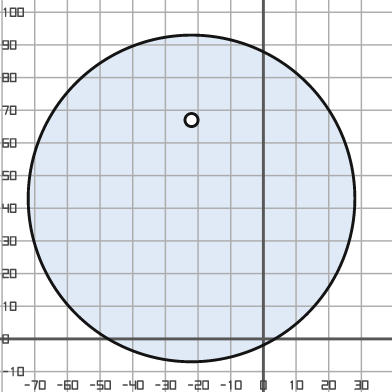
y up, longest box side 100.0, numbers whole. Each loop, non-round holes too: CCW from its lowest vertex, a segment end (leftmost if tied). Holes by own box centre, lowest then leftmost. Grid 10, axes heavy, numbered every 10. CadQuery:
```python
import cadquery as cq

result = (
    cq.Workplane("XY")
    .moveTo(-22.0, 43.0)
    .circle(50.0)
    .moveTo(-22.0, 67.0)
    .circle(2.0)
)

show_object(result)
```